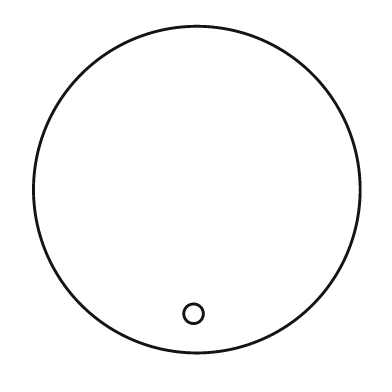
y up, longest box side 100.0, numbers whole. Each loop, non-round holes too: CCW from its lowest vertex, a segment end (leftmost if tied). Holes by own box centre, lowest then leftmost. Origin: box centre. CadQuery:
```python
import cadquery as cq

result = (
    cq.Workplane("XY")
    .moveTo(0.0, 0.0)
    .circle(50.0)
    .moveTo(-1.0, -38.0)
    .circle(3.0)
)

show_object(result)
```